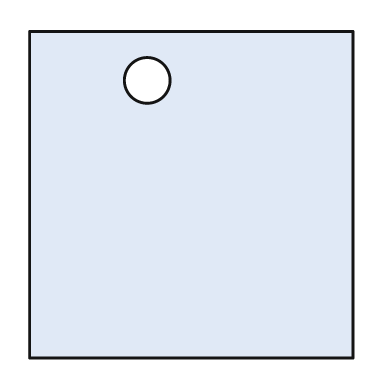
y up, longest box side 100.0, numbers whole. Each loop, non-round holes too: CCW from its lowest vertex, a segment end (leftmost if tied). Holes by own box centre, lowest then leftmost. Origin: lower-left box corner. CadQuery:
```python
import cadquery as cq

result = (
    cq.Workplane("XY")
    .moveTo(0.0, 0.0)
    .lineTo(99.0, 0.0)
    .lineTo(99.0, 100.0)
    .lineTo(0.0, 100.0)
    .close()
    .moveTo(36.0, 85.0)
    .circle(7.0)
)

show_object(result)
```